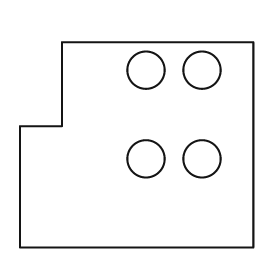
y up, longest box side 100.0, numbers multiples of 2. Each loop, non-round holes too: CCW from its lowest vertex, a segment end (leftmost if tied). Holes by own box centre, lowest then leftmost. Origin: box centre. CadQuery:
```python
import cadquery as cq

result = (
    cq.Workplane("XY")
    .moveTo(-50.0, -44.0)
    .lineTo(50.0, -44.0)
    .lineTo(50.0, 44.0)
    .lineTo(-32.0, 44.0)
    .lineTo(-32.0, 8.0)
    .lineTo(-50.0, 8.0)
    .close()
    .moveTo(4.0, -6.0)
    .circle(8.0)
    .moveTo(28.0, -6.0)
    .circle(8.0)
    .moveTo(4.0, 32.0)
    .circle(8.0)
    .moveTo(28.0, 32.0)
    .circle(8.0)
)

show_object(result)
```